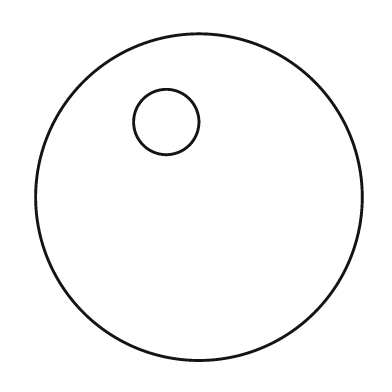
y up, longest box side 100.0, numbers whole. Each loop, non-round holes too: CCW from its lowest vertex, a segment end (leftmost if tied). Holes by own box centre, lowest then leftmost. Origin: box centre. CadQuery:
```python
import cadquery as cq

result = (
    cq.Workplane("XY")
    .moveTo(0.0, 0.0)
    .circle(50.0)
    .moveTo(-10.0, 23.0)
    .circle(10.0)
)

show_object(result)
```